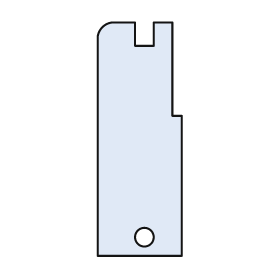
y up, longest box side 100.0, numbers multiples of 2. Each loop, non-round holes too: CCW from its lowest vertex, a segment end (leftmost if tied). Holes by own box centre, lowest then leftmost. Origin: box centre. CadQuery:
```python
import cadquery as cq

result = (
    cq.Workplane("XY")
    .moveTo(-18.0, -50.0)
    .lineTo(18.0, -50.0)
    .lineTo(18.0, 10.0)
    .lineTo(14.0, 10.0)
    .lineTo(14.0, 50.0)
    .lineTo(6.0, 50.0)
    .lineTo(6.0, 40.0)
    .lineTo(-2.0, 40.0)
    .lineTo(-2.0, 50.0)
    .lineTo(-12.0, 50.0)
    .threePointArc((-16.0, 48.0), (-18.0, 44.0))
    .close()
    .moveTo(2.0, -42.0)
    .circle(4.0)
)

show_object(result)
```